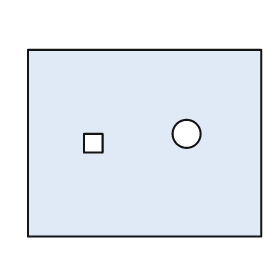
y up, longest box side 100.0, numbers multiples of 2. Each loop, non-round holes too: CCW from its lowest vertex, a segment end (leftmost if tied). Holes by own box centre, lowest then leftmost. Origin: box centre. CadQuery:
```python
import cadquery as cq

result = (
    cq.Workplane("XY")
    .moveTo(-50.0, -40.0)
    .lineTo(50.0, -40.0)
    .lineTo(50.0, 40.0)
    .lineTo(-50.0, 40.0)
    .close()
    .moveTo(-26.0, -4.0)
    .lineTo(-18.0, -4.0)
    .lineTo(-18.0, 4.0)
    .lineTo(-26.0, 4.0)
    .close()
    .moveTo(18.0, 4.0)
    .circle(6.0)
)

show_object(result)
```